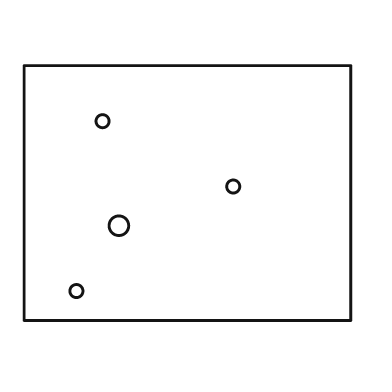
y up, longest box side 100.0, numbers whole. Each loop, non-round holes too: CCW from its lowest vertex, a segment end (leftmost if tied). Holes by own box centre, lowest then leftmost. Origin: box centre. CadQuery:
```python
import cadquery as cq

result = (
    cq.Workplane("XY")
    .moveTo(-50.0, -39.0)
    .lineTo(50.0, -39.0)
    .lineTo(50.0, 39.0)
    .lineTo(-50.0, 39.0)
    .close()
    .moveTo(-34.0, -30.0)
    .circle(2.0)
    .moveTo(-21.0, -10.0)
    .circle(3.0)
    .moveTo(14.0, 2.0)
    .circle(2.0)
    .moveTo(-26.0, 22.0)
    .circle(2.0)
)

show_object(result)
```